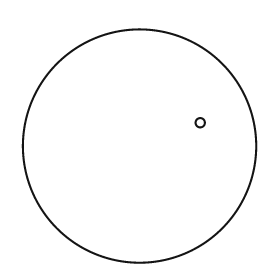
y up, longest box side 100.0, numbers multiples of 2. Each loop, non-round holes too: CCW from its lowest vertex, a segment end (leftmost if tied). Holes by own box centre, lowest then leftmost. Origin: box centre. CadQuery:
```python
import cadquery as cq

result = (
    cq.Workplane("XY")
    .moveTo(0.0, 0.0)
    .circle(50.0)
    .moveTo(26.0, 10.0)
    .circle(2.0)
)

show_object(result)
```